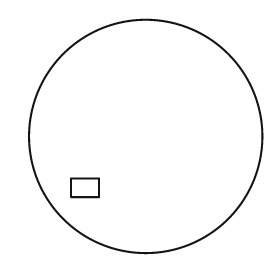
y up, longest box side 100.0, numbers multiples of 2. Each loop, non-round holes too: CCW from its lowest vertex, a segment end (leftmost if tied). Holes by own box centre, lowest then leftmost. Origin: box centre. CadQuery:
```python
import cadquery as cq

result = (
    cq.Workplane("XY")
    .moveTo(0.0, 0.0)
    .circle(50.0)
    .moveTo(-32.0, -26.0)
    .lineTo(-20.0, -26.0)
    .lineTo(-20.0, -18.0)
    .lineTo(-32.0, -18.0)
    .close()
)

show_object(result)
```